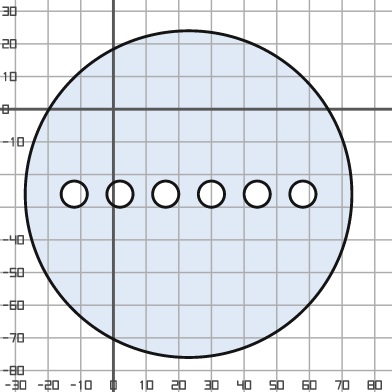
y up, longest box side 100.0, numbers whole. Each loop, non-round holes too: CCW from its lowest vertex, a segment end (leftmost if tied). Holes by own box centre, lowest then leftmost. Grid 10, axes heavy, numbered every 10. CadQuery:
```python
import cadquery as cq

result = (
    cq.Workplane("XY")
    .moveTo(23.0, -26.0)
    .circle(50.0)
    .moveTo(-12.0, -26.0)
    .circle(4.0)
    .moveTo(2.0, -26.0)
    .circle(4.0)
    .moveTo(16.0, -26.0)
    .circle(4.0)
    .moveTo(30.0, -26.0)
    .circle(4.0)
    .moveTo(44.0, -26.0)
    .circle(4.0)
    .moveTo(58.0, -26.0)
    .circle(4.0)
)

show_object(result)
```